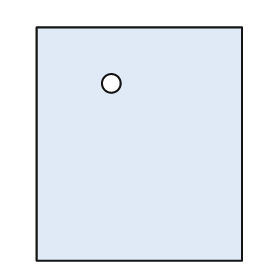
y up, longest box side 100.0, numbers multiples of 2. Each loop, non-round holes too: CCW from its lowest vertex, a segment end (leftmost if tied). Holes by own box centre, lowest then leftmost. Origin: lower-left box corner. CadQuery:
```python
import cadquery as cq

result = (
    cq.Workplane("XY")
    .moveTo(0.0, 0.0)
    .lineTo(88.0, 0.0)
    .lineTo(88.0, 100.0)
    .lineTo(0.0, 100.0)
    .close()
    .moveTo(32.0, 76.0)
    .circle(4.0)
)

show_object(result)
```